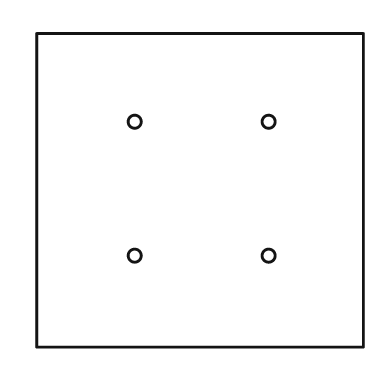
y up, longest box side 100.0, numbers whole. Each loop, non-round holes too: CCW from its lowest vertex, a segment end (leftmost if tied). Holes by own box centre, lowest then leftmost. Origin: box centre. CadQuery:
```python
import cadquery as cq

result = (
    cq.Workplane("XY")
    .moveTo(-50.0, -48.0)
    .lineTo(50.0, -48.0)
    .lineTo(50.0, 48.0)
    .lineTo(-50.0, 48.0)
    .close()
    .moveTo(-20.0, -20.0)
    .circle(2.0)
    .moveTo(21.0, -20.0)
    .circle(2.0)
    .moveTo(-20.0, 21.0)
    .circle(2.0)
    .moveTo(21.0, 21.0)
    .circle(2.0)
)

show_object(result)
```